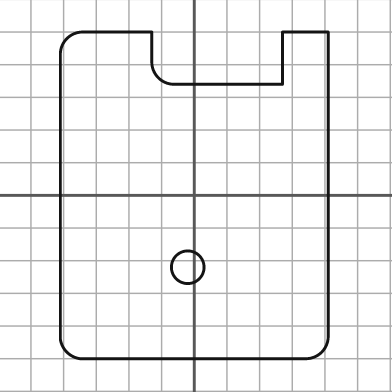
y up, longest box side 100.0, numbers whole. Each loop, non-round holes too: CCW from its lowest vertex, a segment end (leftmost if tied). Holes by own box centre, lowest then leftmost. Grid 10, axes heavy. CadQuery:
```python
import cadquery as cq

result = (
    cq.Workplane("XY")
    .moveTo(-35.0, -50.0)
    .lineTo(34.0, -50.0)
    .threePointArc((39.0, -48.0), (41.0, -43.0))
    .lineTo(41.0, 50.0)
    .lineTo(27.0, 50.0)
    .lineTo(27.0, 34.0)
    .lineTo(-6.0, 34.0)
    .threePointArc((-11.0, 36.0), (-13.0, 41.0))
    .lineTo(-13.0, 50.0)
    .lineTo(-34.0, 50.0)
    .threePointArc((-39.0, 48.0), (-41.0, 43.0))
    .lineTo(-41.0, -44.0)
    .threePointArc((-39.0, -48.0), (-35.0, -50.0))
    .close()
    .moveTo(-2.0, -22.0)
    .circle(5.0)
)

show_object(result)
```